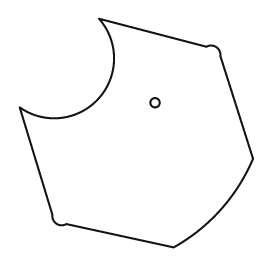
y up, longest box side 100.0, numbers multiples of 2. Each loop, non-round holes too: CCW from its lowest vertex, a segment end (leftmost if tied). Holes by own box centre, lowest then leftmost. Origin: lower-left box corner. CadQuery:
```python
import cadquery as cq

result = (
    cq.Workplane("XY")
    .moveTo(66.0, 0.0)
    .threePointArc((86.0, 16.0), (100.0, 38.0))
    .lineTo(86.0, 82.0)
    .threePointArc((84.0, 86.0), (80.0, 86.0))
    .lineTo(34.0, 98.0)
    .threePointArc((34.0, 64.0), (0.0, 60.0))
    .lineTo(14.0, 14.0)
    .threePointArc((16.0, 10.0), (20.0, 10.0))
    .close()
    .moveTo(58.0, 62.0)
    .circle(2.0)
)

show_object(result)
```